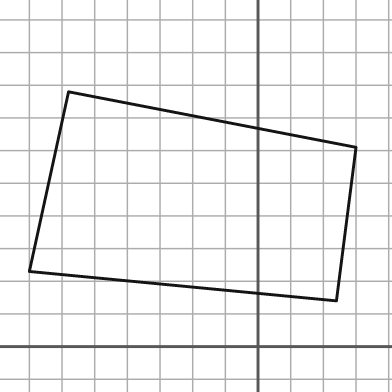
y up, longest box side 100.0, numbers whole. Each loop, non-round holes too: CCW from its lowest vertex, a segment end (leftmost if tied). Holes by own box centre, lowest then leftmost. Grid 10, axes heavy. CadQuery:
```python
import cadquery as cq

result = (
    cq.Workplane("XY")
    .moveTo(24.0, 14.0)
    .lineTo(30.0, 61.0)
    .lineTo(-58.0, 78.0)
    .lineTo(-70.0, 23.0)
    .close()
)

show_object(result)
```